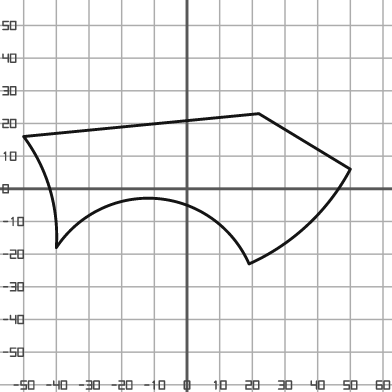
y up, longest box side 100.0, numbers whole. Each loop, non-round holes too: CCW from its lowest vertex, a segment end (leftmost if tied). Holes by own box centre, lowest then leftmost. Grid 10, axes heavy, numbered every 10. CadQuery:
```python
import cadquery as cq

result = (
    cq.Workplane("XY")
    .moveTo(19.0, -23.0)
    .threePointArc((37.0, -11.0), (50.0, 6.0))
    .lineTo(22.0, 23.0)
    .lineTo(-50.0, 16.0)
    .threePointArc((-42.0, 0.0), (-40.0, -18.0))
    .threePointArc((-9.0, -3.0), (19.0, -23.0))
    .close()
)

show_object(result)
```